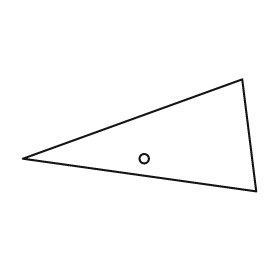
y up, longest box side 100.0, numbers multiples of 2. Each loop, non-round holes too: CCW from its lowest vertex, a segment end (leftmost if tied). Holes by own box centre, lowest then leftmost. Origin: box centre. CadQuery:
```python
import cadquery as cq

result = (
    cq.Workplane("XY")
    .moveTo(50.0, -24.0)
    .lineTo(44.0, 24.0)
    .lineTo(-50.0, -10.0)
    .close()
    .moveTo(2.0, -10.0)
    .circle(2.0)
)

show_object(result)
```